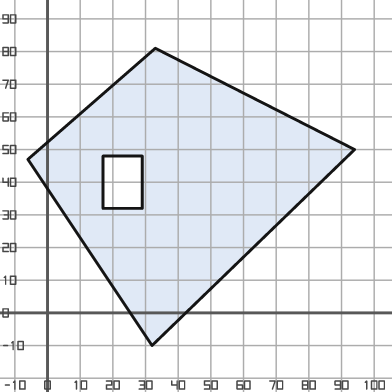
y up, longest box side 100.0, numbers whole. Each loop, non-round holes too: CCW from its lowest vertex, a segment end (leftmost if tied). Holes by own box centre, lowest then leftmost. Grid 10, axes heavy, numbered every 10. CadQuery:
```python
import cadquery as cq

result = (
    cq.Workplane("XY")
    .moveTo(32.0, -10.0)
    .lineTo(94.0, 50.0)
    .lineTo(33.0, 81.0)
    .lineTo(-6.0, 47.0)
    .close()
    .moveTo(17.0, 32.0)
    .lineTo(29.0, 32.0)
    .lineTo(29.0, 48.0)
    .lineTo(17.0, 48.0)
    .close()
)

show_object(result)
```